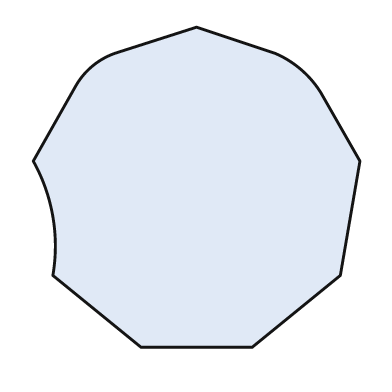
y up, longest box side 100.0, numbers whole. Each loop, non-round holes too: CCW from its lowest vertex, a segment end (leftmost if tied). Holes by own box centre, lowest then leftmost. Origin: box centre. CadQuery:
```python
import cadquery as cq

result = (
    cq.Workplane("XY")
    .moveTo(-17.0, -49.0)
    .lineTo(17.0, -49.0)
    .lineTo(44.0, -27.0)
    .lineTo(50.0, 8.0)
    .lineTo(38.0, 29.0)
    .threePointArc((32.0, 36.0), (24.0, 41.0))
    .lineTo(0.0, 49.0)
    .lineTo(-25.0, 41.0)
    .threePointArc((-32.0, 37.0), (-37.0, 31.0))
    .lineTo(-50.0, 8.0)
    .threePointArc((-44.0, -9.0), (-44.0, -27.0))
    .close()
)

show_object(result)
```